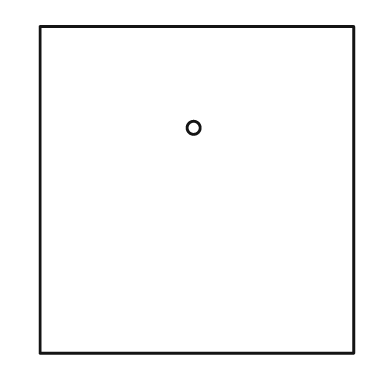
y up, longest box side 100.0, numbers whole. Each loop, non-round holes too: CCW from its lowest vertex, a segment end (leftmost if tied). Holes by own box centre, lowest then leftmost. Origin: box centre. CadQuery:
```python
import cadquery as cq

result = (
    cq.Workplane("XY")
    .moveTo(-48.0, -50.0)
    .lineTo(48.0, -50.0)
    .lineTo(48.0, 50.0)
    .lineTo(-48.0, 50.0)
    .close()
    .moveTo(-1.0, 19.0)
    .circle(2.0)
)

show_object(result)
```